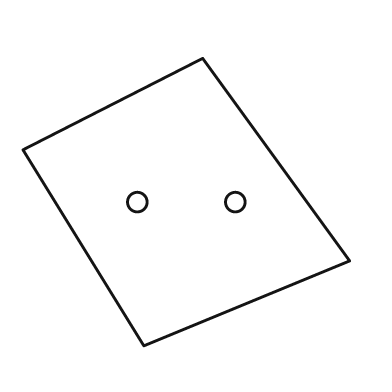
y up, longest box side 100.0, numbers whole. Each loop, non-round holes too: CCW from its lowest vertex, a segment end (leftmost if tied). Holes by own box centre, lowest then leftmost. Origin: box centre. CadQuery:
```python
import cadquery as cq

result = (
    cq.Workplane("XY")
    .moveTo(-13.0, -44.0)
    .lineTo(50.0, -18.0)
    .lineTo(5.0, 44.0)
    .lineTo(-50.0, 16.0)
    .close()
    .moveTo(-15.0, 0.0)
    .circle(3.0)
    .moveTo(15.0, 0.0)
    .circle(3.0)
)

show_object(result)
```